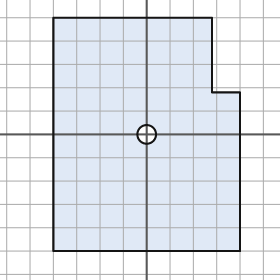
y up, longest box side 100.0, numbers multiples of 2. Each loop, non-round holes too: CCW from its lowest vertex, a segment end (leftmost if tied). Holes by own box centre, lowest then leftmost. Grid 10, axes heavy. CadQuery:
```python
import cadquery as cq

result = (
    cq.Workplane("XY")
    .moveTo(-40.0, -50.0)
    .lineTo(40.0, -50.0)
    .lineTo(40.0, 18.0)
    .lineTo(28.0, 18.0)
    .lineTo(28.0, 50.0)
    .lineTo(-40.0, 50.0)
    .close()
    .moveTo(0.0, 0.0)
    .circle(4.0)
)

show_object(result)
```